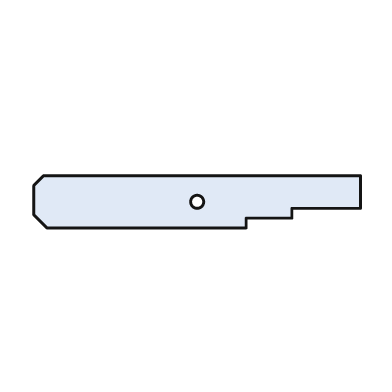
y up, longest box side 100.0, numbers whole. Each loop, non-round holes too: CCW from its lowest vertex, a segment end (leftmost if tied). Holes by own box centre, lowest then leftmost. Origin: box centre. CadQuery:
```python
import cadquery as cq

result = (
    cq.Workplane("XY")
    .moveTo(-46.0, -8.0)
    .lineTo(15.0, -8.0)
    .lineTo(15.0, -5.0)
    .lineTo(29.0, -5.0)
    .lineTo(29.0, -2.0)
    .lineTo(50.0, -2.0)
    .lineTo(50.0, 8.0)
    .lineTo(-47.0, 8.0)
    .lineTo(-50.0, 5.0)
    .lineTo(-50.0, -4.0)
    .close()
    .moveTo(0.0, 0.0)
    .circle(2.0)
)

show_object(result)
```